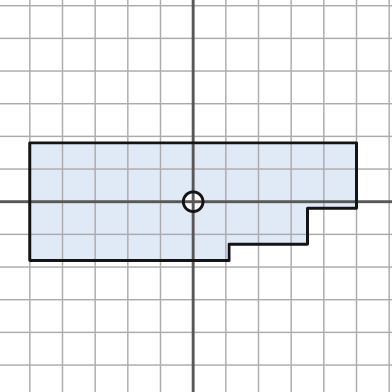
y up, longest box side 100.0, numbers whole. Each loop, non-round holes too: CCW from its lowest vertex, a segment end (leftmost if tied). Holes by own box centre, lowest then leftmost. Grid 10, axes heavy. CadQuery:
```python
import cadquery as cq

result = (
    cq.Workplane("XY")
    .moveTo(-50.0, -18.0)
    .lineTo(11.0, -18.0)
    .lineTo(11.0, -13.0)
    .lineTo(35.0, -13.0)
    .lineTo(35.0, -2.0)
    .lineTo(50.0, -2.0)
    .lineTo(50.0, 18.0)
    .lineTo(-50.0, 18.0)
    .close()
    .moveTo(0.0, 0.0)
    .circle(3.0)
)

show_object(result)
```